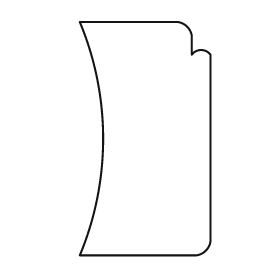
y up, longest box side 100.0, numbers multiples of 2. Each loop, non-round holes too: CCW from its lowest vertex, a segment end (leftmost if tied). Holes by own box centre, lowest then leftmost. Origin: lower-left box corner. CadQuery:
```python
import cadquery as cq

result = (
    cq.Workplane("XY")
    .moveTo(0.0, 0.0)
    .lineTo(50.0, 0.0)
    .threePointArc((54.0, 2.0), (56.0, 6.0))
    .lineTo(56.0, 86.0)
    .threePointArc((52.0, 88.0), (48.0, 86.0))
    .lineTo(48.0, 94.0)
    .threePointArc((46.0, 98.0), (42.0, 100.0))
    .lineTo(0.0, 100.0)
    .threePointArc((10.0, 50.0), (0.0, 0.0))
    .close()
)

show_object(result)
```